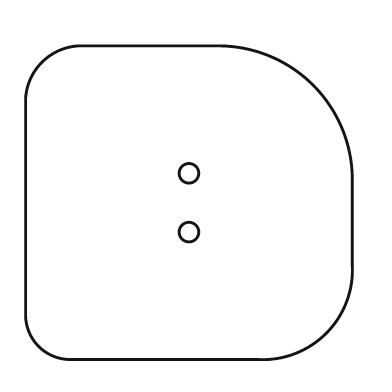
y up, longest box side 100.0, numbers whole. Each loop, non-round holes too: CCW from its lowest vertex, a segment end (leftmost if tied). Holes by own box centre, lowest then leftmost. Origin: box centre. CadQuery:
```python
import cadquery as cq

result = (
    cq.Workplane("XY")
    .moveTo(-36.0, -48.0)
    .lineTo(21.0, -48.0)
    .threePointArc((42.0, -40.0), (50.0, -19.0))
    .lineTo(50.0, 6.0)
    .threePointArc((38.0, 36.0), (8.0, 48.0))
    .lineTo(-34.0, 48.0)
    .threePointArc((-45.0, 43.0), (-50.0, 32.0))
    .lineTo(-50.0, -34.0)
    .threePointArc((-46.0, -44.0), (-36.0, -48.0))
    .close()
    .moveTo(0.0, -9.0)
    .circle(3.0)
    .moveTo(0.0, 9.0)
    .circle(3.0)
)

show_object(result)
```